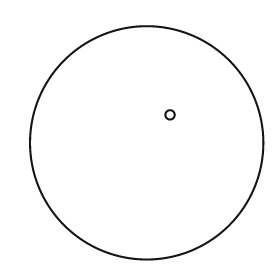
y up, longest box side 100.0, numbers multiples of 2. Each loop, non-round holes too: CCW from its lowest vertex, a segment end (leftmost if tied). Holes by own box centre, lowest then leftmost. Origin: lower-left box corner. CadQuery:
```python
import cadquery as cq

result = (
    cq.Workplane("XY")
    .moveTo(50.0, 50.0)
    .circle(50.0)
    .moveTo(60.0, 62.0)
    .circle(2.0)
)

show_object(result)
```